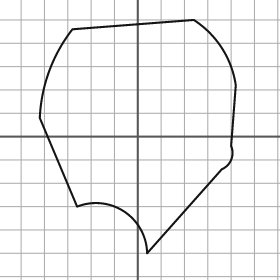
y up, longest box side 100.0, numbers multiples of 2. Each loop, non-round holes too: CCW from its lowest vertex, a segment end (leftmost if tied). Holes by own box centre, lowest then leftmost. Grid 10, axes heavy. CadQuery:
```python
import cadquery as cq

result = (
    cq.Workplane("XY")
    .moveTo(4.0, -50.0)
    .lineTo(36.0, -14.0)
    .threePointArc((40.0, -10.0), (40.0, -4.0))
    .lineTo(42.0, 22.0)
    .threePointArc((36.0, 38.0), (24.0, 50.0))
    .lineTo(-28.0, 46.0)
    .threePointArc((-38.0, 28.0), (-42.0, 8.0))
    .lineTo(-26.0, -30.0)
    .threePointArc((-6.0, -32.0), (4.0, -50.0))
    .close()
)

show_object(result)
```